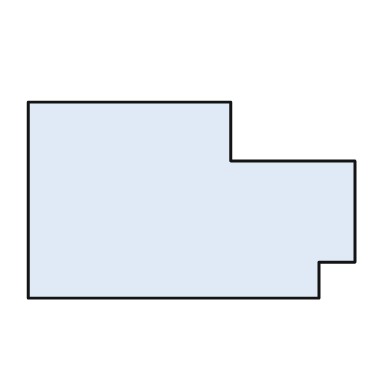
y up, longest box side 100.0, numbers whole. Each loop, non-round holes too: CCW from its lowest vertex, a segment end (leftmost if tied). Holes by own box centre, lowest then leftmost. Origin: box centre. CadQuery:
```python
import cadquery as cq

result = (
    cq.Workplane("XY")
    .moveTo(-50.0, -30.0)
    .lineTo(39.0, -30.0)
    .lineTo(39.0, -19.0)
    .lineTo(50.0, -19.0)
    .lineTo(50.0, 12.0)
    .lineTo(12.0, 12.0)
    .lineTo(12.0, 30.0)
    .lineTo(-50.0, 30.0)
    .close()
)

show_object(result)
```